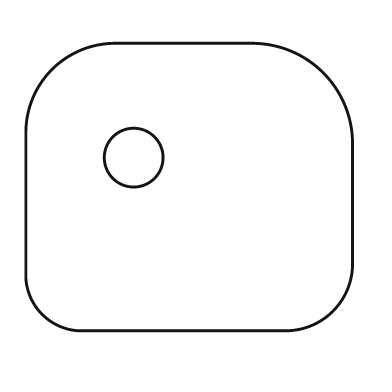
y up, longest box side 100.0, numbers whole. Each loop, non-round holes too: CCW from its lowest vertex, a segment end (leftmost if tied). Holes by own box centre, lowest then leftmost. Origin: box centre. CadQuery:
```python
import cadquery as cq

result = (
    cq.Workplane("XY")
    .moveTo(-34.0, -44.0)
    .lineTo(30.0, -44.0)
    .threePointArc((44.0, -38.0), (50.0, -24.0))
    .lineTo(50.0, 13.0)
    .threePointArc((41.0, 35.0), (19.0, 44.0))
    .lineTo(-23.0, 44.0)
    .threePointArc((-42.0, 36.0), (-50.0, 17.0))
    .lineTo(-50.0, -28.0)
    .threePointArc((-45.0, -39.0), (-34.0, -44.0))
    .close()
    .moveTo(-17.0, 9.0)
    .circle(9.0)
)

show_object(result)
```